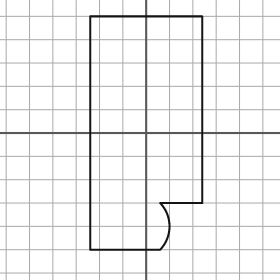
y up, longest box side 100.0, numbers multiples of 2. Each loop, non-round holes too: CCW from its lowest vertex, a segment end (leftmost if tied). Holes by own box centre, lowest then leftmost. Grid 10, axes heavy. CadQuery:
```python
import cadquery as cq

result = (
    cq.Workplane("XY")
    .moveTo(-24.0, -50.0)
    .lineTo(6.0, -50.0)
    .threePointArc((10.0, -40.0), (6.0, -30.0))
    .lineTo(24.0, -30.0)
    .lineTo(24.0, 50.0)
    .lineTo(-24.0, 50.0)
    .close()
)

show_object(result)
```